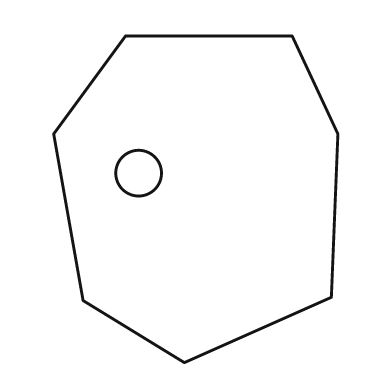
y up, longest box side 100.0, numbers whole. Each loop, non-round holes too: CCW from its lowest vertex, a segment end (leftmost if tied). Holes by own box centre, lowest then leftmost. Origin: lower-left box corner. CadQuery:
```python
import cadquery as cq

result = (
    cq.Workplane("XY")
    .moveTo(40.0, 0.0)
    .lineTo(85.0, 20.0)
    .lineTo(87.0, 70.0)
    .lineTo(73.0, 100.0)
    .lineTo(22.0, 100.0)
    .lineTo(0.0, 70.0)
    .lineTo(9.0, 19.0)
    .close()
    .moveTo(26.0, 58.0)
    .circle(7.0)
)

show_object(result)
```